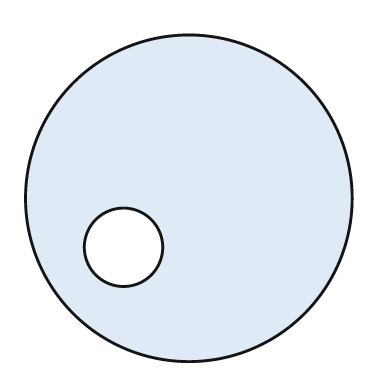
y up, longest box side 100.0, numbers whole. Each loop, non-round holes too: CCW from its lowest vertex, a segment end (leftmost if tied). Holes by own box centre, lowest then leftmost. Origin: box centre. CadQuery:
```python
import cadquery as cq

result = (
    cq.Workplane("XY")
    .moveTo(0.0, 0.0)
    .circle(50.0)
    .moveTo(-20.0, -15.0)
    .circle(12.0)
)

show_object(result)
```